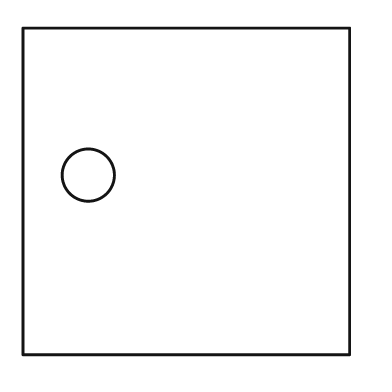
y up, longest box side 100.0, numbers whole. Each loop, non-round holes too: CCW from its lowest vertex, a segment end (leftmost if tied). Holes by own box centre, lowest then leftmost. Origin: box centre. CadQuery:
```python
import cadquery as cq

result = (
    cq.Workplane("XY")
    .moveTo(-50.0, -50.0)
    .lineTo(50.0, -50.0)
    .lineTo(50.0, 50.0)
    .lineTo(-50.0, 50.0)
    .close()
    .moveTo(-30.0, 5.0)
    .circle(8.0)
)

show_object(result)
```